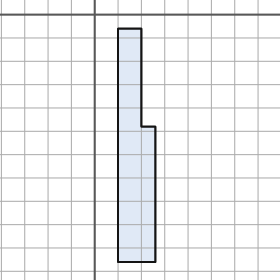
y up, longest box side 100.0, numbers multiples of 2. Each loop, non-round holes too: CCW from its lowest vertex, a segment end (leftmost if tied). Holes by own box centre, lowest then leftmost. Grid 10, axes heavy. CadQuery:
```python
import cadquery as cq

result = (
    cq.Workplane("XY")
    .moveTo(10.0, -106.0)
    .lineTo(26.0, -106.0)
    .lineTo(26.0, -48.0)
    .lineTo(20.0, -48.0)
    .lineTo(20.0, -6.0)
    .lineTo(10.0, -6.0)
    .close()
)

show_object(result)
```